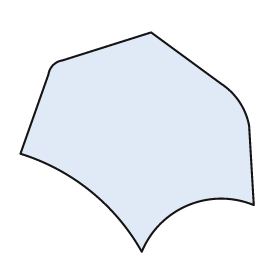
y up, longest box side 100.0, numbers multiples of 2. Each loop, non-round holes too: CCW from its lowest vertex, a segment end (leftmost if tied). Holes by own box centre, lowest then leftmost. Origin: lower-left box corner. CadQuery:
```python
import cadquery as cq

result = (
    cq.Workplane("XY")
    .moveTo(52.0, 0.0)
    .threePointArc((72.0, 20.0), (100.0, 20.0))
    .lineTo(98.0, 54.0)
    .threePointArc((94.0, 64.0), (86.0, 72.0))
    .lineTo(56.0, 94.0)
    .lineTo(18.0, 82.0)
    .threePointArc((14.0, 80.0), (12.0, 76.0))
    .lineTo(0.0, 42.0)
    .threePointArc((30.0, 26.0), (52.0, 0.0))
    .close()
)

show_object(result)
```